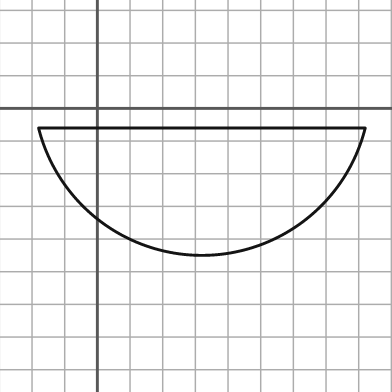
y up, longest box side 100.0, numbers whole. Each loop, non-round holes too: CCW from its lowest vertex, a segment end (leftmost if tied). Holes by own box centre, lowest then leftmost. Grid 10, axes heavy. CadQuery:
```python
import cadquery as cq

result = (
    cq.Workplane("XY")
    .moveTo(-18.0, -6.0)
    .threePointArc((32.0, -45.0), (82.0, -6.0))
    .close()
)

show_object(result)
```